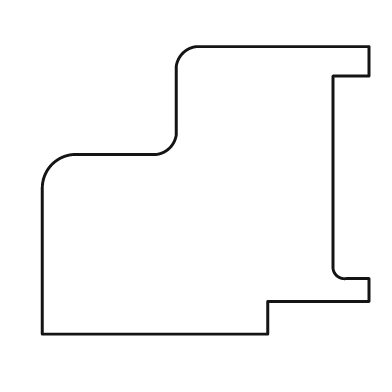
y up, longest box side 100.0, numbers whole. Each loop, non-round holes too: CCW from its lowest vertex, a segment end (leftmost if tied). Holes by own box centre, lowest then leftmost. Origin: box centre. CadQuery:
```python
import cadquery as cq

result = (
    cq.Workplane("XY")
    .moveTo(-50.0, -44.0)
    .lineTo(19.0, -44.0)
    .lineTo(19.0, -34.0)
    .lineTo(50.0, -34.0)
    .lineTo(50.0, -27.0)
    .lineTo(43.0, -27.0)
    .threePointArc((40.0, -26.0), (39.0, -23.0))
    .lineTo(39.0, 35.0)
    .lineTo(50.0, 35.0)
    .lineTo(50.0, 44.0)
    .lineTo(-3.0, 44.0)
    .threePointArc((-7.0, 42.0), (-9.0, 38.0))
    .lineTo(-9.0, 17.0)
    .threePointArc((-11.0, 13.0), (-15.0, 11.0))
    .lineTo(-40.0, 11.0)
    .threePointArc((-47.0, 8.0), (-50.0, 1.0))
    .close()
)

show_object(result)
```